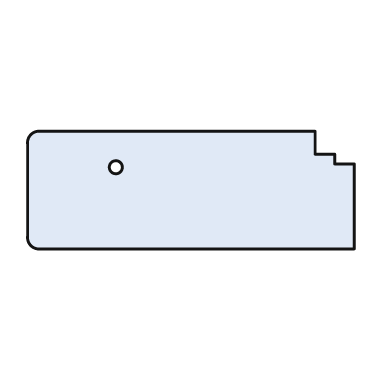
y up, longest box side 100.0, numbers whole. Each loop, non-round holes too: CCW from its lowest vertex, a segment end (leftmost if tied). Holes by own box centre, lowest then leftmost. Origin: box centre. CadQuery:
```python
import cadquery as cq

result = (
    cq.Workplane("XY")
    .moveTo(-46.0, -18.0)
    .lineTo(50.0, -18.0)
    .lineTo(50.0, 8.0)
    .lineTo(44.0, 8.0)
    .lineTo(44.0, 11.0)
    .lineTo(38.0, 11.0)
    .lineTo(38.0, 18.0)
    .lineTo(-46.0, 18.0)
    .threePointArc((-49.0, 17.0), (-50.0, 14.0))
    .lineTo(-50.0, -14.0)
    .threePointArc((-49.0, -17.0), (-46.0, -18.0))
    .close()
    .moveTo(-23.0, 7.0)
    .circle(2.0)
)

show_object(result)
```